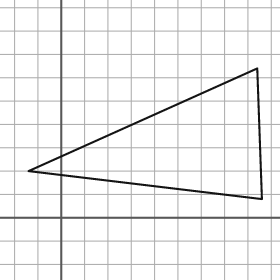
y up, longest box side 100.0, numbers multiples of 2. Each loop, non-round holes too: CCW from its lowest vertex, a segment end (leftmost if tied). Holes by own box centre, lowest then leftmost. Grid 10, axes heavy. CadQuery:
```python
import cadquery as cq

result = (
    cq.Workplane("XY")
    .moveTo(86.0, 8.0)
    .lineTo(84.0, 64.0)
    .lineTo(-14.0, 20.0)
    .close()
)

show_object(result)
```